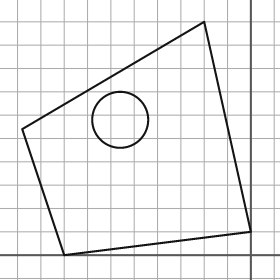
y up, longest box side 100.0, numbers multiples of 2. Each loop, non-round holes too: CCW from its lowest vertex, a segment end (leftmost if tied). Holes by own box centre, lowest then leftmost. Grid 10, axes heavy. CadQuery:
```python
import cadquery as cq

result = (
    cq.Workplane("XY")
    .moveTo(-80.0, 0.0)
    .lineTo(0.0, 10.0)
    .lineTo(-20.0, 100.0)
    .lineTo(-98.0, 54.0)
    .close()
    .moveTo(-56.0, 58.0)
    .circle(12.0)
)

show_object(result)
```